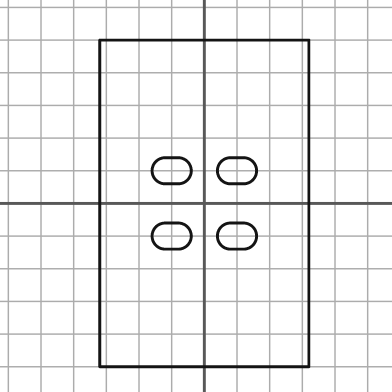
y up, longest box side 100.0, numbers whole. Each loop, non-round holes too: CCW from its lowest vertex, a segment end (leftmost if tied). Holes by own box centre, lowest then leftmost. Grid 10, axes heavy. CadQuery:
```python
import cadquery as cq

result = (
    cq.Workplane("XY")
    .moveTo(-32.0, -50.0)
    .lineTo(32.0, -50.0)
    .lineTo(32.0, 50.0)
    .lineTo(-32.0, 50.0)
    .close()
    .moveTo(-12.0, -14.0)
    .lineTo(-8.0, -14.0)
    .threePointArc((-4.0, -10.0), (-8.0, -6.0))
    .lineTo(-12.0, -6.0)
    .threePointArc((-16.0, -10.0), (-12.0, -14.0))
    .close()
    .moveTo(8.0, -14.0)
    .lineTo(12.0, -14.0)
    .threePointArc((16.0, -10.0), (12.0, -6.0))
    .lineTo(8.0, -6.0)
    .threePointArc((4.0, -10.0), (8.0, -14.0))
    .close()
    .moveTo(-12.0, 6.0)
    .lineTo(-8.0, 6.0)
    .threePointArc((-4.0, 10.0), (-8.0, 14.0))
    .lineTo(-12.0, 14.0)
    .threePointArc((-16.0, 10.0), (-12.0, 6.0))
    .close()
    .moveTo(8.0, 6.0)
    .lineTo(12.0, 6.0)
    .threePointArc((16.0, 10.0), (12.0, 14.0))
    .lineTo(8.0, 14.0)
    .threePointArc((4.0, 10.0), (8.0, 6.0))
    .close()
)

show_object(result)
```